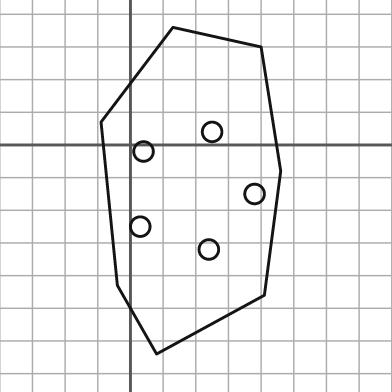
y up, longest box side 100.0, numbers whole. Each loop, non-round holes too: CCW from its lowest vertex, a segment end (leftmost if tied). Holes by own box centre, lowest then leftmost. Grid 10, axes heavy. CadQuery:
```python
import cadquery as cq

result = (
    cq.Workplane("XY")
    .moveTo(8.0, -64.0)
    .lineTo(41.0, -46.0)
    .lineTo(46.0, -8.0)
    .lineTo(40.0, 30.0)
    .lineTo(13.0, 36.0)
    .lineTo(-9.0, 7.0)
    .lineTo(-4.0, -43.0)
    .close()
    .moveTo(24.0, -32.0)
    .circle(3.0)
    .moveTo(3.0, -25.0)
    .circle(3.0)
    .moveTo(38.0, -15.0)
    .circle(3.0)
    .moveTo(4.0, -2.0)
    .circle(3.0)
    .moveTo(25.0, 4.0)
    .circle(3.0)
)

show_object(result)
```